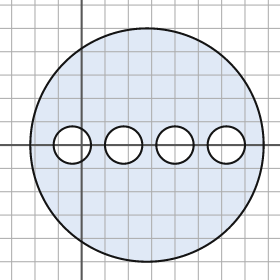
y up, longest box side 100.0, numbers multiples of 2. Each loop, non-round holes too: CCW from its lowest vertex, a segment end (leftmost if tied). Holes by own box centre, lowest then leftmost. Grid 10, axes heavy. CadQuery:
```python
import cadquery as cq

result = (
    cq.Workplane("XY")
    .moveTo(28.0, 0.0)
    .circle(50.0)
    .moveTo(-4.0, 0.0)
    .circle(8.0)
    .moveTo(18.0, 0.0)
    .circle(8.0)
    .moveTo(40.0, 0.0)
    .circle(8.0)
    .moveTo(62.0, 0.0)
    .circle(8.0)
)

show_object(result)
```